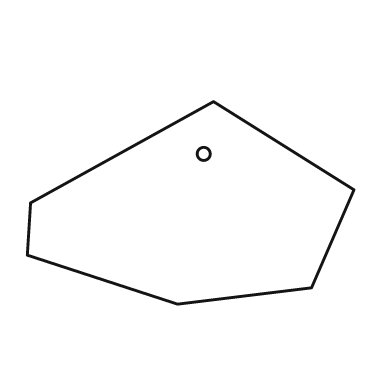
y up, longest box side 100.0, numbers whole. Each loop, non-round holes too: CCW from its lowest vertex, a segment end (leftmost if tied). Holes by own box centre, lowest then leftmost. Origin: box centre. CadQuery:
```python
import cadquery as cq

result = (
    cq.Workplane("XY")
    .moveTo(-4.0, -31.0)
    .lineTo(37.0, -26.0)
    .lineTo(50.0, 4.0)
    .lineTo(7.0, 31.0)
    .lineTo(-49.0, 0.0)
    .lineTo(-50.0, -16.0)
    .close()
    .moveTo(4.0, 15.0)
    .circle(2.0)
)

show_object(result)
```